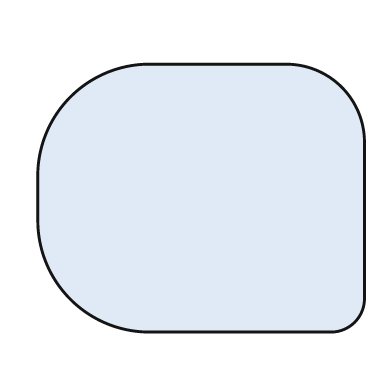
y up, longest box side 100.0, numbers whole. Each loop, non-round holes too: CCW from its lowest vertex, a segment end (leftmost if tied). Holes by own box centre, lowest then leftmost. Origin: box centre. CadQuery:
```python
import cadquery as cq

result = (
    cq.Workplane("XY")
    .moveTo(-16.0, -41.0)
    .lineTo(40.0, -41.0)
    .threePointArc((47.0, -38.0), (50.0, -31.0))
    .lineTo(50.0, 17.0)
    .threePointArc((43.0, 34.0), (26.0, 41.0))
    .lineTo(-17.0, 41.0)
    .threePointArc((-40.0, 31.0), (-50.0, 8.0))
    .lineTo(-50.0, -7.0)
    .threePointArc((-40.0, -31.0), (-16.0, -41.0))
    .close()
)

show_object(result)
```